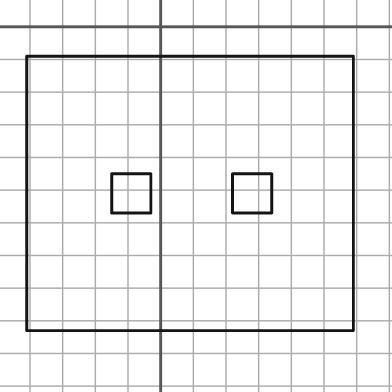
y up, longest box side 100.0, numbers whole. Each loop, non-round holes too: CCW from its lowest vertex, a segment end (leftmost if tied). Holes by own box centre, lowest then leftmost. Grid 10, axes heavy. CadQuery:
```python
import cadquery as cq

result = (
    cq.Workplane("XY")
    .moveTo(-41.0, -93.0)
    .lineTo(59.0, -93.0)
    .lineTo(59.0, -9.0)
    .lineTo(-41.0, -9.0)
    .close()
    .moveTo(-15.0, -57.0)
    .lineTo(-3.0, -57.0)
    .lineTo(-3.0, -45.0)
    .lineTo(-15.0, -45.0)
    .close()
    .moveTo(22.0, -57.0)
    .lineTo(34.0, -57.0)
    .lineTo(34.0, -45.0)
    .lineTo(22.0, -45.0)
    .close()
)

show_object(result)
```